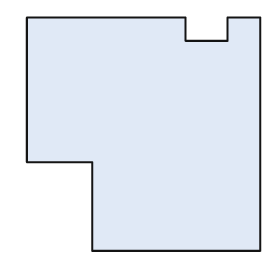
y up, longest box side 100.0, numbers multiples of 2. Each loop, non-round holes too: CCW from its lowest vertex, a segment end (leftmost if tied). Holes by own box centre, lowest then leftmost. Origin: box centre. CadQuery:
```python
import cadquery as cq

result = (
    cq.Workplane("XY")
    .moveTo(-22.0, -50.0)
    .lineTo(50.0, -50.0)
    .lineTo(50.0, 50.0)
    .lineTo(36.0, 50.0)
    .lineTo(36.0, 40.0)
    .lineTo(18.0, 40.0)
    .lineTo(18.0, 50.0)
    .lineTo(-50.0, 50.0)
    .lineTo(-50.0, -12.0)
    .lineTo(-22.0, -12.0)
    .close()
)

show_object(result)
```